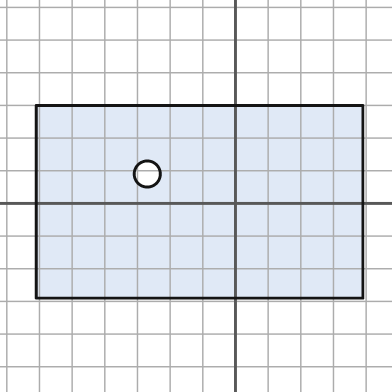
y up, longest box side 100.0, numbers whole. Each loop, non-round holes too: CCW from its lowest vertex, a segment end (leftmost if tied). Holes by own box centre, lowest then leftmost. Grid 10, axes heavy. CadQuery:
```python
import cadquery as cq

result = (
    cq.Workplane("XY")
    .moveTo(-61.0, -29.0)
    .lineTo(39.0, -29.0)
    .lineTo(39.0, 30.0)
    .lineTo(-61.0, 30.0)
    .close()
    .moveTo(-27.0, 9.0)
    .circle(4.0)
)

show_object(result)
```